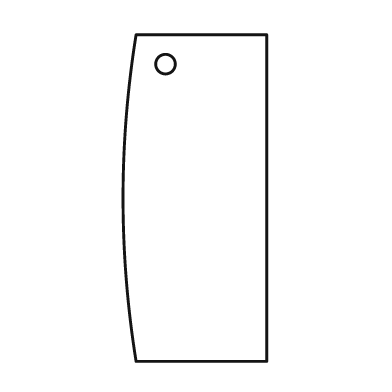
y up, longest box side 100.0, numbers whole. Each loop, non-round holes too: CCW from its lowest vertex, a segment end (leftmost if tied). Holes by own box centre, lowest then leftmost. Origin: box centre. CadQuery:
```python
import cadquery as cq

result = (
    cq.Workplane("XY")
    .moveTo(-18.0, -50.0)
    .lineTo(22.0, -50.0)
    .lineTo(22.0, 50.0)
    .lineTo(-18.0, 50.0)
    .threePointArc((-22.0, 0.0), (-18.0, -50.0))
    .close()
    .moveTo(-9.0, 41.0)
    .circle(3.0)
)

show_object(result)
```